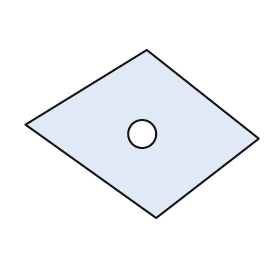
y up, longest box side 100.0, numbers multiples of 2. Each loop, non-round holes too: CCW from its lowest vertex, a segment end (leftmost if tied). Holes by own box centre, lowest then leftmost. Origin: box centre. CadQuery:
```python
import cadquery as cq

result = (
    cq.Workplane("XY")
    .moveTo(6.0, -36.0)
    .lineTo(50.0, -2.0)
    .lineTo(2.0, 36.0)
    .lineTo(-50.0, 4.0)
    .close()
    .moveTo(0.0, 0.0)
    .circle(6.0)
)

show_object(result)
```